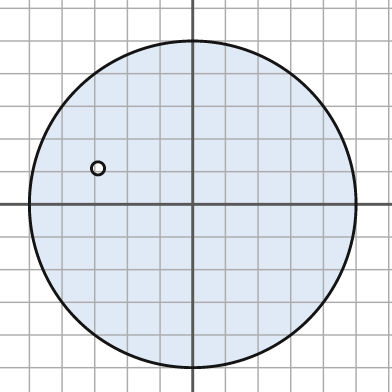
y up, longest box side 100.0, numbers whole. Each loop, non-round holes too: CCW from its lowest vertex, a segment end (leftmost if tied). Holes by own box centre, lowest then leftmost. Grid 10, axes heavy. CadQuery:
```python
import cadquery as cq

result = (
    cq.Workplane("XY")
    .moveTo(0.0, 0.0)
    .circle(50.0)
    .moveTo(-29.0, 11.0)
    .circle(2.0)
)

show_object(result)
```